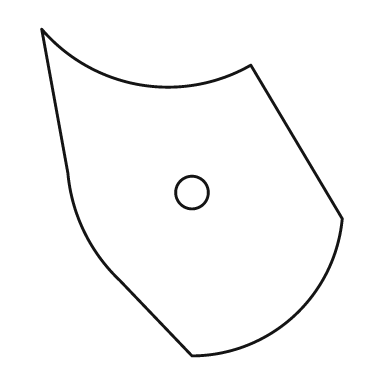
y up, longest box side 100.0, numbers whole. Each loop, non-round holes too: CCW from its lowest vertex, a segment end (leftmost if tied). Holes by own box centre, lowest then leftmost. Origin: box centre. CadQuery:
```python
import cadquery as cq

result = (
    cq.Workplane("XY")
    .moveTo(0.0, -50.0)
    .threePointArc((31.0, -38.0), (46.0, -8.0))
    .lineTo(18.0, 39.0)
    .threePointArc((-16.0, 33.0), (-46.0, 50.0))
    .lineTo(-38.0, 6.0)
    .threePointArc((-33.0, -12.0), (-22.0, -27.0))
    .close()
    .moveTo(0.0, 0.0)
    .circle(5.0)
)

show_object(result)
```